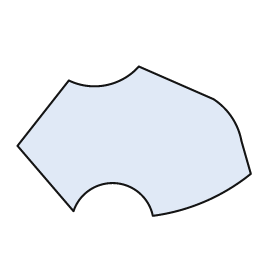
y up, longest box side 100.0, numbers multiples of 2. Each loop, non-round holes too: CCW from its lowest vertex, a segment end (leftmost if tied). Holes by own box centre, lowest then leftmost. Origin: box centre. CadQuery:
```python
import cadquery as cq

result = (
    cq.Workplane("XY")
    .moveTo(8.0, -32.0)
    .threePointArc((30.0, -26.0), (50.0, -14.0))
    .lineTo(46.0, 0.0)
    .threePointArc((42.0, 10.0), (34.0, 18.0))
    .lineTo(2.0, 32.0)
    .threePointArc((-12.0, 24.0), (-28.0, 26.0))
    .lineTo(-50.0, -2.0)
    .lineTo(-26.0, -30.0)
    .threePointArc((-8.0, -18.0), (8.0, -32.0))
    .close()
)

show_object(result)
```